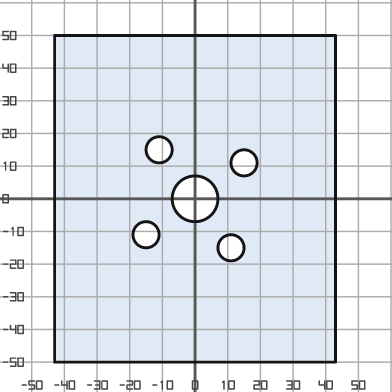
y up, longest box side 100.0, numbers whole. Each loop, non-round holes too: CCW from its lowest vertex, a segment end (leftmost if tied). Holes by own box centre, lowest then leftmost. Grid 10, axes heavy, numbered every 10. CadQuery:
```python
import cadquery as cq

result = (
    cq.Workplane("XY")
    .moveTo(-43.0, -50.0)
    .lineTo(43.0, -50.0)
    .lineTo(43.0, 50.0)
    .lineTo(-43.0, 50.0)
    .close()
    .moveTo(11.0, -15.0)
    .circle(4.0)
    .moveTo(-15.0, -11.0)
    .circle(4.0)
    .moveTo(0.0, 0.0)
    .circle(7.0)
    .moveTo(15.0, 11.0)
    .circle(4.0)
    .moveTo(-11.0, 15.0)
    .circle(4.0)
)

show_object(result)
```